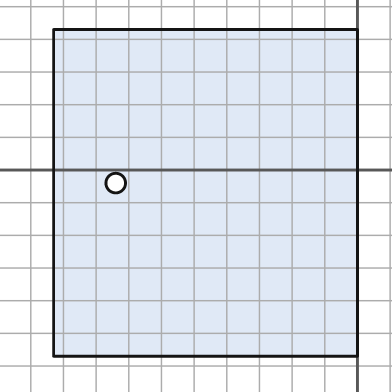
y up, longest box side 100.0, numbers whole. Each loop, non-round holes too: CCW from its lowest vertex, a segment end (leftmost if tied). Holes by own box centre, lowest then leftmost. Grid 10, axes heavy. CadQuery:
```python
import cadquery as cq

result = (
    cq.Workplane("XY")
    .moveTo(-93.0, -57.0)
    .lineTo(0.0, -57.0)
    .lineTo(0.0, 43.0)
    .lineTo(-93.0, 43.0)
    .close()
    .moveTo(-74.0, -4.0)
    .circle(3.0)
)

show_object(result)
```